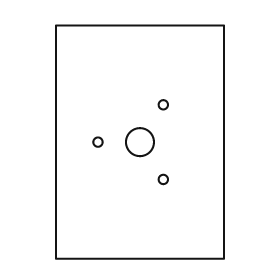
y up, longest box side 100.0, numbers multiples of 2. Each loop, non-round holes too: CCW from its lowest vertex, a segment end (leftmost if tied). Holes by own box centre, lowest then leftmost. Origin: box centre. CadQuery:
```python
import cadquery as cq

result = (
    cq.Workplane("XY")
    .moveTo(-36.0, -50.0)
    .lineTo(36.0, -50.0)
    .lineTo(36.0, 50.0)
    .lineTo(-36.0, 50.0)
    .close()
    .moveTo(10.0, -16.0)
    .circle(2.0)
    .moveTo(-18.0, 0.0)
    .circle(2.0)
    .moveTo(0.0, 0.0)
    .circle(6.0)
    .moveTo(10.0, 16.0)
    .circle(2.0)
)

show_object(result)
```